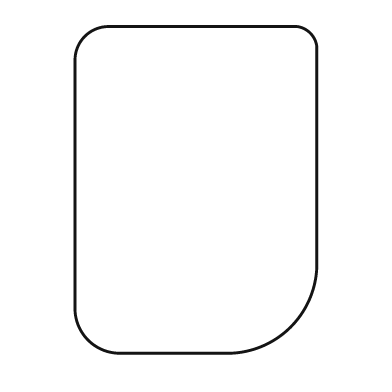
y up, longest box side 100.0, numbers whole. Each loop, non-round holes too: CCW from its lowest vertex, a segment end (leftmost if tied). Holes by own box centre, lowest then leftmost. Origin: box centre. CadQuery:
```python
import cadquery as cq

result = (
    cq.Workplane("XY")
    .moveTo(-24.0, -50.0)
    .lineTo(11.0, -50.0)
    .threePointArc((29.0, -42.0), (37.0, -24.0))
    .lineTo(37.0, 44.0)
    .threePointArc((35.0, 48.0), (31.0, 50.0))
    .lineTo(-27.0, 50.0)
    .threePointArc((-34.0, 47.0), (-37.0, 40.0))
    .lineTo(-37.0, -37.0)
    .threePointArc((-33.0, -46.0), (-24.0, -50.0))
    .close()
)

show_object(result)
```